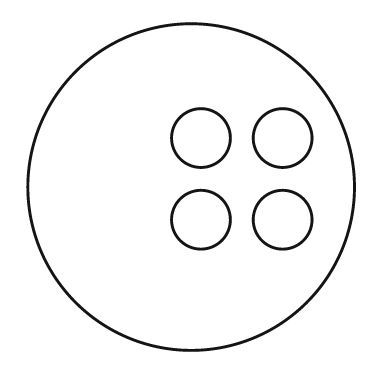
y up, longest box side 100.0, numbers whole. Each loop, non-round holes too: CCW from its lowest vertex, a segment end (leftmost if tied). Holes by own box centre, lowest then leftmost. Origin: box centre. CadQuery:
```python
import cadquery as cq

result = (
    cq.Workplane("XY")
    .moveTo(0.0, 0.0)
    .circle(50.0)
    .moveTo(3.0, -10.0)
    .circle(9.0)
    .moveTo(28.0, -10.0)
    .circle(9.0)
    .moveTo(3.0, 15.0)
    .circle(9.0)
    .moveTo(28.0, 15.0)
    .circle(9.0)
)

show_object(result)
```